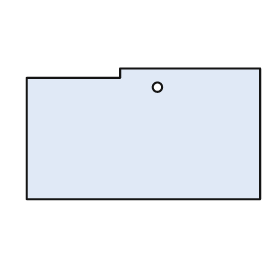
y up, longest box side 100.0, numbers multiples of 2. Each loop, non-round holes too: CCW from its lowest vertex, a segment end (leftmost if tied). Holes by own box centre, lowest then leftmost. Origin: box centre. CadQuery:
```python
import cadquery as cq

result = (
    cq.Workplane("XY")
    .moveTo(-50.0, -28.0)
    .lineTo(50.0, -28.0)
    .lineTo(50.0, 28.0)
    .lineTo(-10.0, 28.0)
    .lineTo(-10.0, 24.0)
    .lineTo(-50.0, 24.0)
    .close()
    .moveTo(6.0, 20.0)
    .circle(2.0)
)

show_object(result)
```